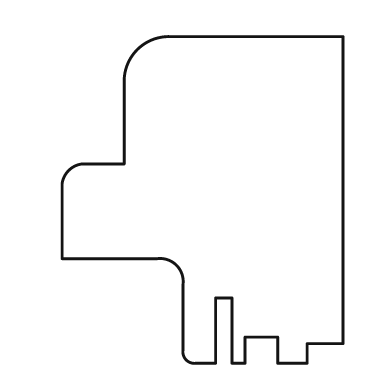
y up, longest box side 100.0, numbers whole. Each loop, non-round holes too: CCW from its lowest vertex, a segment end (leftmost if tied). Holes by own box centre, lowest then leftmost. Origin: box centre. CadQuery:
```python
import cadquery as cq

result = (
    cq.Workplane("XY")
    .moveTo(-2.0, -50.0)
    .lineTo(4.0, -50.0)
    .lineTo(4.0, -30.0)
    .lineTo(9.0, -30.0)
    .lineTo(9.0, -50.0)
    .lineTo(13.0, -50.0)
    .lineTo(13.0, -42.0)
    .lineTo(23.0, -42.0)
    .lineTo(23.0, -50.0)
    .lineTo(32.0, -50.0)
    .lineTo(32.0, -44.0)
    .lineTo(43.0, -44.0)
    .lineTo(43.0, 50.0)
    .lineTo(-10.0, 50.0)
    .threePointArc((-20.0, 46.0), (-24.0, 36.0))
    .lineTo(-24.0, 11.0)
    .lineTo(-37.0, 11.0)
    .threePointArc((-41.0, 9.0), (-43.0, 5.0))
    .lineTo(-43.0, -18.0)
    .lineTo(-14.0, -18.0)
    .threePointArc((-8.0, -20.0), (-6.0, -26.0))
    .lineTo(-6.0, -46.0)
    .threePointArc((-5.0, -49.0), (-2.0, -50.0))
    .close()
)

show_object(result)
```